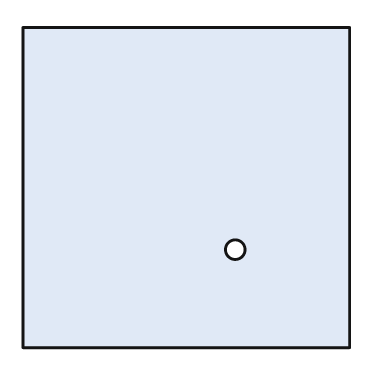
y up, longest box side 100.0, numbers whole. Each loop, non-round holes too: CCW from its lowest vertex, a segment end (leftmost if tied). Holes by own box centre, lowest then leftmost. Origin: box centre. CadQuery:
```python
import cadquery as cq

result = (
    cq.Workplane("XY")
    .moveTo(-50.0, -49.0)
    .lineTo(50.0, -49.0)
    .lineTo(50.0, 49.0)
    .lineTo(-50.0, 49.0)
    .close()
    .moveTo(15.0, -19.0)
    .circle(3.0)
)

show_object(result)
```